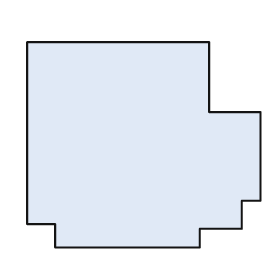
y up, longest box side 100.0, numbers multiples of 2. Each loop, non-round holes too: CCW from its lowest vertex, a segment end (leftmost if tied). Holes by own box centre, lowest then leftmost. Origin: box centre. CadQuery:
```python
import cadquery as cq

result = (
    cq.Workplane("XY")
    .moveTo(-38.0, -44.0)
    .lineTo(24.0, -44.0)
    .lineTo(24.0, -36.0)
    .lineTo(42.0, -36.0)
    .lineTo(42.0, -24.0)
    .lineTo(50.0, -24.0)
    .lineTo(50.0, 14.0)
    .lineTo(28.0, 14.0)
    .lineTo(28.0, 44.0)
    .lineTo(-50.0, 44.0)
    .lineTo(-50.0, -34.0)
    .lineTo(-38.0, -34.0)
    .close()
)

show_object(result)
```